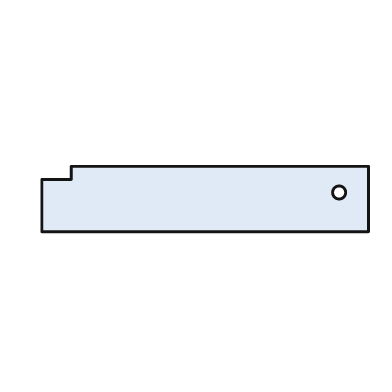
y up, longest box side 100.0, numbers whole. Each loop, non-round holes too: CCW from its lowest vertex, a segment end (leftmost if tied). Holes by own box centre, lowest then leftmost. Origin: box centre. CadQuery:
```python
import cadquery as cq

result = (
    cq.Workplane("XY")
    .moveTo(-50.0, -10.0)
    .lineTo(50.0, -10.0)
    .lineTo(50.0, 10.0)
    .lineTo(-41.0, 10.0)
    .lineTo(-41.0, 6.0)
    .lineTo(-50.0, 6.0)
    .close()
    .moveTo(41.0, 2.0)
    .circle(2.0)
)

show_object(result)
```